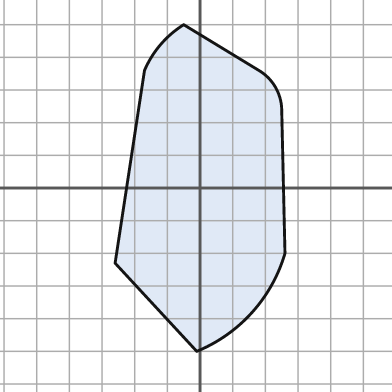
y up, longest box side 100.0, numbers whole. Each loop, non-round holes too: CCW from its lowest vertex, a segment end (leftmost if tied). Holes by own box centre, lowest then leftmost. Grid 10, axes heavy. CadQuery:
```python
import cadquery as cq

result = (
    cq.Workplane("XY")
    .moveTo(-1.0, -50.0)
    .threePointArc((16.0, -38.0), (26.0, -20.0))
    .lineTo(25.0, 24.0)
    .threePointArc((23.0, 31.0), (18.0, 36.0))
    .lineTo(-5.0, 50.0)
    .threePointArc((-12.0, 44.0), (-17.0, 36.0))
    .lineTo(-26.0, -23.0)
    .close()
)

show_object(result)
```